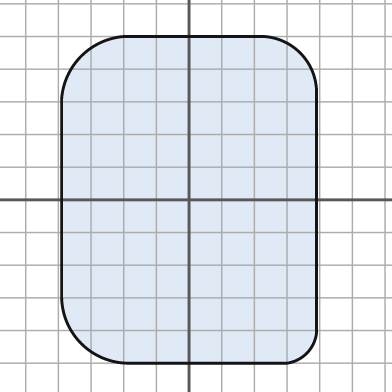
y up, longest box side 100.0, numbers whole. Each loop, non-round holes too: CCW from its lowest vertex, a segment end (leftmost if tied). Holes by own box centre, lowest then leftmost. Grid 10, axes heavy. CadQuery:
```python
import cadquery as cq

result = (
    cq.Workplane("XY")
    .moveTo(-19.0, -50.0)
    .lineTo(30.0, -50.0)
    .threePointArc((36.0, -47.0), (39.0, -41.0))
    .lineTo(39.0, 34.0)
    .threePointArc((34.0, 45.0), (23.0, 50.0))
    .lineTo(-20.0, 50.0)
    .threePointArc((-33.0, 44.0), (-39.0, 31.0))
    .lineTo(-39.0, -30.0)
    .threePointArc((-33.0, -44.0), (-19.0, -50.0))
    .close()
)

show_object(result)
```